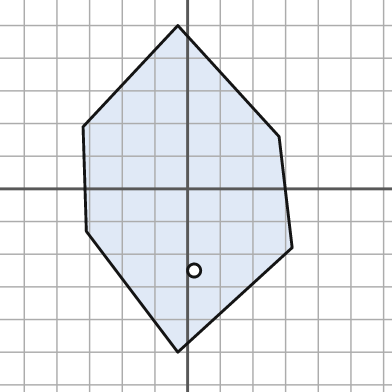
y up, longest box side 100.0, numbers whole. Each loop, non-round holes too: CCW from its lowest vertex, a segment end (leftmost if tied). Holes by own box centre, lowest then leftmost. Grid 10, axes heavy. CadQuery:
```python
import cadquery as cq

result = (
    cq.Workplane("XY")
    .moveTo(-3.0, -50.0)
    .lineTo(32.0, -18.0)
    .lineTo(28.0, 16.0)
    .lineTo(-3.0, 50.0)
    .lineTo(-32.0, 19.0)
    .lineTo(-31.0, -13.0)
    .close()
    .moveTo(2.0, -25.0)
    .circle(2.0)
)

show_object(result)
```